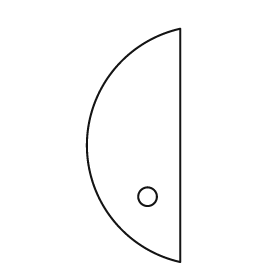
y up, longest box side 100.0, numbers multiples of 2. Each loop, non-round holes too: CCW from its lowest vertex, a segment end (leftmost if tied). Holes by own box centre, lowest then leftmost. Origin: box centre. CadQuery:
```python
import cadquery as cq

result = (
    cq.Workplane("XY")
    .moveTo(20.0, -50.0)
    .lineTo(20.0, 50.0)
    .threePointArc((-20.0, 0.0), (20.0, -50.0))
    .close()
    .moveTo(6.0, -22.0)
    .circle(4.0)
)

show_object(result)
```